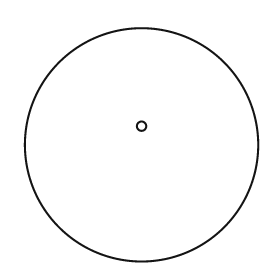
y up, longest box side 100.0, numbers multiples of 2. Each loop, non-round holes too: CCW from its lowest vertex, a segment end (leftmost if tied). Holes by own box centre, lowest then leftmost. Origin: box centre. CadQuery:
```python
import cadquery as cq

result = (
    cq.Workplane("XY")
    .moveTo(0.0, 0.0)
    .circle(50.0)
    .moveTo(0.0, 8.0)
    .circle(2.0)
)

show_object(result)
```